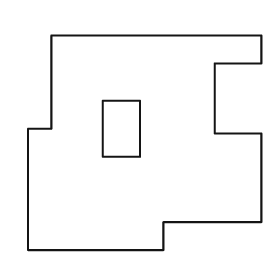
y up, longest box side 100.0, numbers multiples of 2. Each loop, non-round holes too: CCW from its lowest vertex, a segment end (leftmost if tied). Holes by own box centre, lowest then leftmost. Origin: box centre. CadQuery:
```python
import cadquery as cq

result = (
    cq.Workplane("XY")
    .moveTo(-50.0, -46.0)
    .lineTo(8.0, -46.0)
    .lineTo(8.0, -34.0)
    .lineTo(50.0, -34.0)
    .lineTo(50.0, 4.0)
    .lineTo(30.0, 4.0)
    .lineTo(30.0, 34.0)
    .lineTo(50.0, 34.0)
    .lineTo(50.0, 46.0)
    .lineTo(-40.0, 46.0)
    .lineTo(-40.0, 6.0)
    .lineTo(-50.0, 6.0)
    .close()
    .moveTo(-18.0, -6.0)
    .lineTo(-2.0, -6.0)
    .lineTo(-2.0, 18.0)
    .lineTo(-18.0, 18.0)
    .close()
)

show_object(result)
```